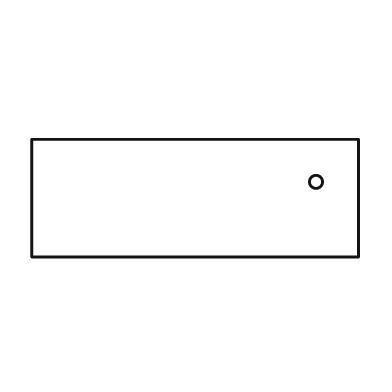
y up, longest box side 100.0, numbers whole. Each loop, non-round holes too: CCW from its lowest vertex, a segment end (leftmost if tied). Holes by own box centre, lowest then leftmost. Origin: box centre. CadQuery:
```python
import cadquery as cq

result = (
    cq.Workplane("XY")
    .moveTo(-50.0, -18.0)
    .lineTo(50.0, -18.0)
    .lineTo(50.0, 18.0)
    .lineTo(-50.0, 18.0)
    .close()
    .moveTo(37.0, 5.0)
    .circle(2.0)
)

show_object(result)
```